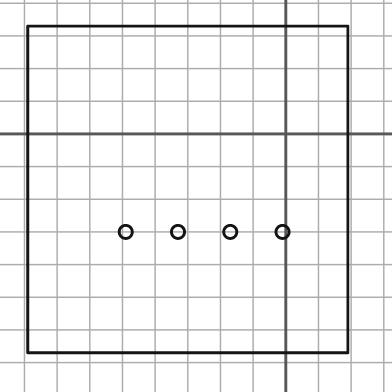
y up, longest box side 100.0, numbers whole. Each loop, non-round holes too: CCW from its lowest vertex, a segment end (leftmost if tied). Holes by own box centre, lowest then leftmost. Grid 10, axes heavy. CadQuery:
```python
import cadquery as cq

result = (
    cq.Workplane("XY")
    .moveTo(-79.0, -67.0)
    .lineTo(19.0, -67.0)
    .lineTo(19.0, 33.0)
    .lineTo(-79.0, 33.0)
    .close()
    .moveTo(-49.0, -30.0)
    .circle(2.0)
    .moveTo(-33.0, -30.0)
    .circle(2.0)
    .moveTo(-17.0, -30.0)
    .circle(2.0)
    .moveTo(-1.0, -30.0)
    .circle(2.0)
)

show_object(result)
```